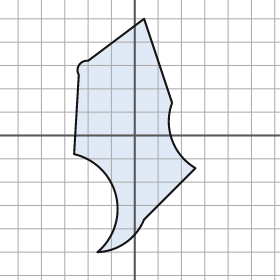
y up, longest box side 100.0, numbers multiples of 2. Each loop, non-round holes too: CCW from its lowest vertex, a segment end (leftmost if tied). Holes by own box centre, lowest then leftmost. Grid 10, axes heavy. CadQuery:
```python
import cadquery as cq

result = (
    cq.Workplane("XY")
    .moveTo(-16.0, -50.0)
    .threePointArc((-4.0, -46.0), (4.0, -36.0))
    .lineTo(26.0, -14.0)
    .threePointArc((16.0, -2.0), (16.0, 14.0))
    .lineTo(4.0, 50.0)
    .lineTo(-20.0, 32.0)
    .threePointArc((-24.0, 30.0), (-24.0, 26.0))
    .lineTo(-26.0, -8.0)
    .threePointArc((-8.0, -26.0), (-16.0, -50.0))
    .close()
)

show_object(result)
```